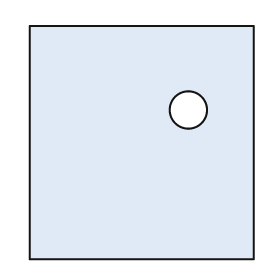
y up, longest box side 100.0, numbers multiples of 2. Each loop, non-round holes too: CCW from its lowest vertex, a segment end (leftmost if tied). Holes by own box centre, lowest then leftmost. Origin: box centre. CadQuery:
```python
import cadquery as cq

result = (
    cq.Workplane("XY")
    .moveTo(-48.0, -50.0)
    .lineTo(48.0, -50.0)
    .lineTo(48.0, 50.0)
    .lineTo(-48.0, 50.0)
    .close()
    .moveTo(20.0, 14.0)
    .circle(8.0)
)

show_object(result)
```